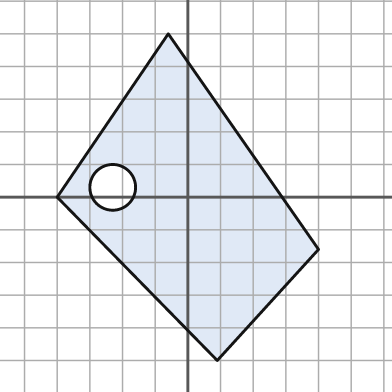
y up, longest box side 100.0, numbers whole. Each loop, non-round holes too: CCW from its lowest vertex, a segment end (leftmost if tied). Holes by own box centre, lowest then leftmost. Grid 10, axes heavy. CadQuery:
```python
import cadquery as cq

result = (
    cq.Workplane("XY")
    .moveTo(9.0, -50.0)
    .lineTo(40.0, -16.0)
    .lineTo(-6.0, 50.0)
    .lineTo(-40.0, 0.0)
    .close()
    .moveTo(-23.0, 3.0)
    .circle(7.0)
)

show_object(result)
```